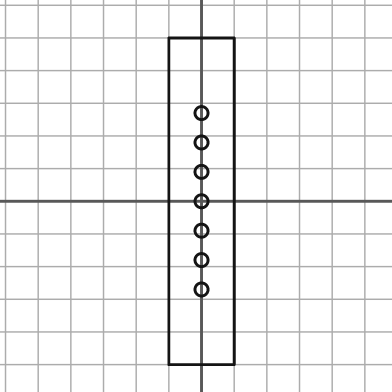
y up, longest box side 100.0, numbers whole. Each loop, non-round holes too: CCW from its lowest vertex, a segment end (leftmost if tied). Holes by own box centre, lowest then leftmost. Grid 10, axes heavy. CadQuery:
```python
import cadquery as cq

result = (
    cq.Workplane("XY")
    .moveTo(-10.0, -50.0)
    .lineTo(10.0, -50.0)
    .lineTo(10.0, 50.0)
    .lineTo(-10.0, 50.0)
    .close()
    .moveTo(0.0, -27.0)
    .circle(2.0)
    .moveTo(0.0, -18.0)
    .circle(2.0)
    .moveTo(0.0, -9.0)
    .circle(2.0)
    .moveTo(0.0, 0.0)
    .circle(2.0)
    .moveTo(0.0, 9.0)
    .circle(2.0)
    .moveTo(0.0, 18.0)
    .circle(2.0)
    .moveTo(0.0, 27.0)
    .circle(2.0)
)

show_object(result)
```